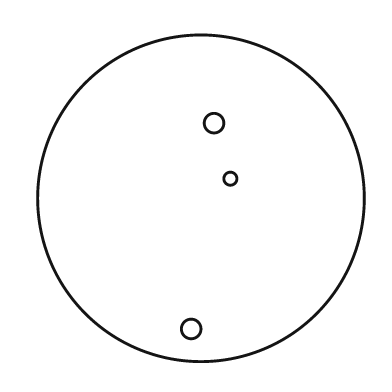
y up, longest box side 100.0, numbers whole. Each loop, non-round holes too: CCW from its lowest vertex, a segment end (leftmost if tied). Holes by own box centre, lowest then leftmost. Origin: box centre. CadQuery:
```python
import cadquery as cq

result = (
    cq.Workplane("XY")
    .moveTo(0.0, 0.0)
    .circle(50.0)
    .moveTo(-3.0, -40.0)
    .circle(3.0)
    .moveTo(9.0, 6.0)
    .circle(2.0)
    .moveTo(4.0, 23.0)
    .circle(3.0)
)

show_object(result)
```